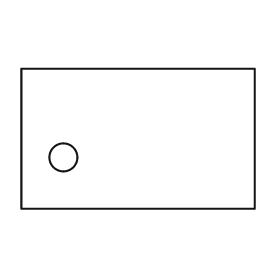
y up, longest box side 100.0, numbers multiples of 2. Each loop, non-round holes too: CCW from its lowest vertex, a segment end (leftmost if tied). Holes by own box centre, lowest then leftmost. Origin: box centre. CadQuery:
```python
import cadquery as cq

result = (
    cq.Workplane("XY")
    .moveTo(-50.0, -30.0)
    .lineTo(50.0, -30.0)
    .lineTo(50.0, 30.0)
    .lineTo(-50.0, 30.0)
    .close()
    .moveTo(-32.0, -8.0)
    .circle(6.0)
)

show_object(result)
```